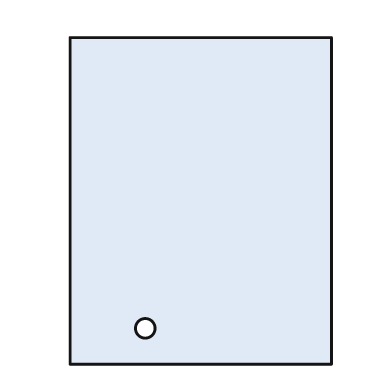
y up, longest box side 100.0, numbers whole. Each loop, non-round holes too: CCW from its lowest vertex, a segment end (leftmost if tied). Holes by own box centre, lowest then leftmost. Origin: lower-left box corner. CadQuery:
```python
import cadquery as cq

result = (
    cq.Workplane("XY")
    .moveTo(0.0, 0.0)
    .lineTo(80.0, 0.0)
    .lineTo(80.0, 100.0)
    .lineTo(0.0, 100.0)
    .close()
    .moveTo(23.0, 11.0)
    .circle(3.0)
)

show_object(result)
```